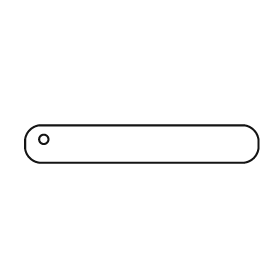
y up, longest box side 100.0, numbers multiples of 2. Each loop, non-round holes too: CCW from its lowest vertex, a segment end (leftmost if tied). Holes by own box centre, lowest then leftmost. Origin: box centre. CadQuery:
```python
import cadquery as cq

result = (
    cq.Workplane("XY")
    .moveTo(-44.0, -8.0)
    .lineTo(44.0, -8.0)
    .threePointArc((48.0, -6.0), (50.0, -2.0))
    .lineTo(50.0, 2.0)
    .threePointArc((48.0, 6.0), (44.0, 8.0))
    .lineTo(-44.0, 8.0)
    .threePointArc((-48.0, 6.0), (-50.0, 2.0))
    .lineTo(-50.0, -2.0)
    .threePointArc((-48.0, -6.0), (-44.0, -8.0))
    .close()
    .moveTo(-42.0, 2.0)
    .circle(2.0)
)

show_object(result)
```